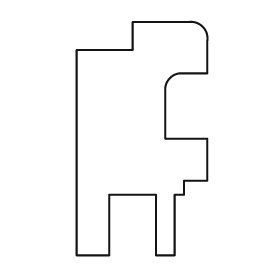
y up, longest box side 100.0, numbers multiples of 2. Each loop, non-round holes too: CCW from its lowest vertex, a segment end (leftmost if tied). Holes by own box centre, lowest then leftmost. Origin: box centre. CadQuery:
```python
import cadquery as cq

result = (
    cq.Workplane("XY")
    .moveTo(-28.0, -50.0)
    .lineTo(-14.0, -50.0)
    .lineTo(-14.0, -24.0)
    .lineTo(6.0, -24.0)
    .lineTo(6.0, -50.0)
    .lineTo(14.0, -50.0)
    .lineTo(14.0, -24.0)
    .lineTo(18.0, -24.0)
    .lineTo(18.0, -18.0)
    .lineTo(28.0, -18.0)
    .lineTo(28.0, 0.0)
    .lineTo(10.0, 0.0)
    .lineTo(10.0, 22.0)
    .threePointArc((12.0, 26.0), (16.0, 28.0))
    .lineTo(28.0, 28.0)
    .lineTo(28.0, 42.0)
    .threePointArc((26.0, 48.0), (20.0, 50.0))
    .lineTo(-4.0, 50.0)
    .lineTo(-4.0, 38.0)
    .lineTo(-28.0, 38.0)
    .close()
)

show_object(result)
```